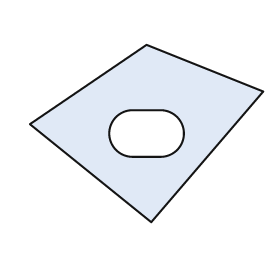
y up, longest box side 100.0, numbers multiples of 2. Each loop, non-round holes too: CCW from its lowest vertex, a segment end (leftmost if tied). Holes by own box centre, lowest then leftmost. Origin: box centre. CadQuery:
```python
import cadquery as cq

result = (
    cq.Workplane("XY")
    .moveTo(2.0, -38.0)
    .lineTo(50.0, 18.0)
    .lineTo(0.0, 38.0)
    .lineTo(-50.0, 4.0)
    .close()
    .moveTo(-6.0, -10.0)
    .lineTo(6.0, -10.0)
    .threePointArc((16.0, 0.0), (6.0, 10.0))
    .lineTo(-6.0, 10.0)
    .threePointArc((-16.0, 0.0), (-6.0, -10.0))
    .close()
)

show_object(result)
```